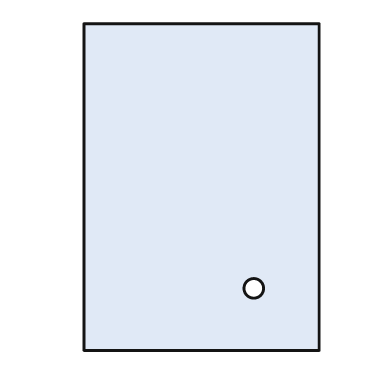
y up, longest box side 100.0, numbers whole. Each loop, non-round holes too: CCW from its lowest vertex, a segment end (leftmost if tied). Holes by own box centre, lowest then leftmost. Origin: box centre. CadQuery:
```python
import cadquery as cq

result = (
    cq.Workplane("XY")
    .moveTo(-36.0, -50.0)
    .lineTo(36.0, -50.0)
    .lineTo(36.0, 50.0)
    .lineTo(-36.0, 50.0)
    .close()
    .moveTo(16.0, -31.0)
    .circle(3.0)
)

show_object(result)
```